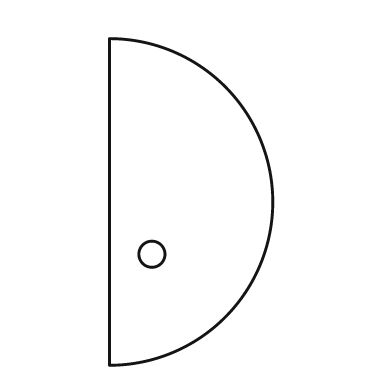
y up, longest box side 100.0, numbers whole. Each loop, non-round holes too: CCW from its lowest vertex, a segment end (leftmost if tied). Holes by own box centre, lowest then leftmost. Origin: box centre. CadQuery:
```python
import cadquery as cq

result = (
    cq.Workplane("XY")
    .moveTo(-25.0, -50.0)
    .threePointArc((25.0, 0.0), (-25.0, 50.0))
    .close()
    .moveTo(-12.0, -16.0)
    .circle(4.0)
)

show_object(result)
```